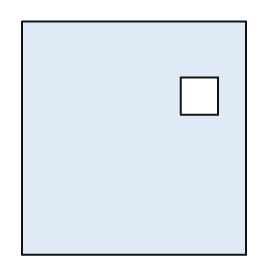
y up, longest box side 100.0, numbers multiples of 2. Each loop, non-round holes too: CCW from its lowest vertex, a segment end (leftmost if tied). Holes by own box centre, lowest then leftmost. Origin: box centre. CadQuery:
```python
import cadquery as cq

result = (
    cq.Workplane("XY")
    .moveTo(-48.0, -50.0)
    .lineTo(48.0, -50.0)
    .lineTo(48.0, 50.0)
    .lineTo(-48.0, 50.0)
    .close()
    .moveTo(20.0, 10.0)
    .lineTo(36.0, 10.0)
    .lineTo(36.0, 26.0)
    .lineTo(20.0, 26.0)
    .close()
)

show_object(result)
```